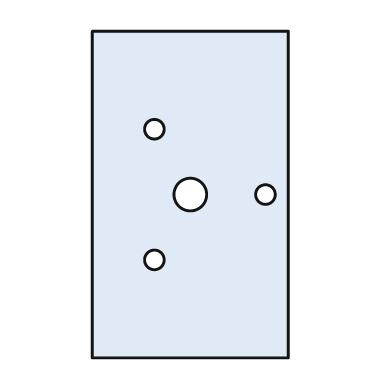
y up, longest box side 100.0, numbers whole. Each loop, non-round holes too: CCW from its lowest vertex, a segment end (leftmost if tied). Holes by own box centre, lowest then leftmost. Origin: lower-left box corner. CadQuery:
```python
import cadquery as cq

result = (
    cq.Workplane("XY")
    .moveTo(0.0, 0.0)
    .lineTo(60.0, 0.0)
    .lineTo(60.0, 100.0)
    .lineTo(0.0, 100.0)
    .close()
    .moveTo(19.0, 30.0)
    .circle(3.0)
    .moveTo(30.0, 50.0)
    .circle(5.0)
    .moveTo(53.0, 50.0)
    .circle(3.0)
    .moveTo(19.0, 70.0)
    .circle(3.0)
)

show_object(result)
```